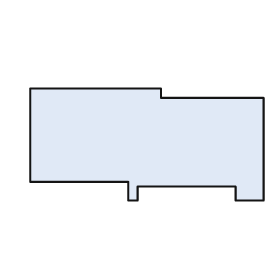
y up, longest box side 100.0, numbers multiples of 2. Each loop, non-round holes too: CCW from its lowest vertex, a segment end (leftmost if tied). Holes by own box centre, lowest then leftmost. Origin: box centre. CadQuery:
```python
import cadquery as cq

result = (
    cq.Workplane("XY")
    .moveTo(-8.0, -24.0)
    .lineTo(-4.0, -24.0)
    .lineTo(-4.0, -18.0)
    .lineTo(38.0, -18.0)
    .lineTo(38.0, -24.0)
    .lineTo(50.0, -24.0)
    .lineTo(50.0, 20.0)
    .lineTo(6.0, 20.0)
    .lineTo(6.0, 24.0)
    .lineTo(-50.0, 24.0)
    .lineTo(-50.0, -16.0)
    .lineTo(-8.0, -16.0)
    .close()
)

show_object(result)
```